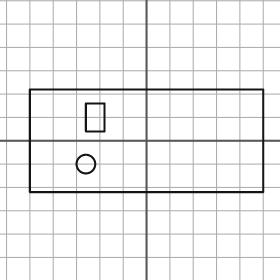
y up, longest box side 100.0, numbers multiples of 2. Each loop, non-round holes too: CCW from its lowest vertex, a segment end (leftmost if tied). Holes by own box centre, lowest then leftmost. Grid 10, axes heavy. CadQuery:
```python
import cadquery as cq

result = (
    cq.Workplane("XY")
    .moveTo(-50.0, -22.0)
    .lineTo(50.0, -22.0)
    .lineTo(50.0, 22.0)
    .lineTo(-50.0, 22.0)
    .close()
    .moveTo(-26.0, -10.0)
    .circle(4.0)
    .moveTo(-26.0, 4.0)
    .lineTo(-18.0, 4.0)
    .lineTo(-18.0, 16.0)
    .lineTo(-26.0, 16.0)
    .close()
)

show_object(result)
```